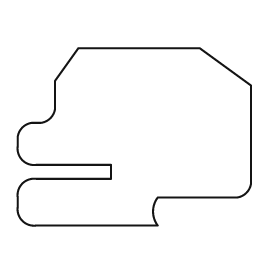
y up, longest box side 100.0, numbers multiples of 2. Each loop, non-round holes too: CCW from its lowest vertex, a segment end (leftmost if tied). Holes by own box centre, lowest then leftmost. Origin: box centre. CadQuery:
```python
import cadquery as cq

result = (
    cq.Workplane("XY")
    .moveTo(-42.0, -38.0)
    .lineTo(10.0, -38.0)
    .threePointArc((8.0, -32.0), (10.0, -26.0))
    .lineTo(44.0, -26.0)
    .threePointArc((48.0, -24.0), (50.0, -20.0))
    .lineTo(50.0, 22.0)
    .lineTo(28.0, 38.0)
    .lineTo(-24.0, 38.0)
    .lineTo(-34.0, 24.0)
    .lineTo(-34.0, 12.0)
    .threePointArc((-36.0, 8.0), (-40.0, 6.0))
    .lineTo(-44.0, 6.0)
    .threePointArc((-48.0, 4.0), (-50.0, 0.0))
    .lineTo(-50.0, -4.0)
    .threePointArc((-48.0, -10.0), (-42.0, -12.0))
    .lineTo(-10.0, -12.0)
    .lineTo(-10.0, -18.0)
    .lineTo(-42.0, -18.0)
    .threePointArc((-48.0, -20.0), (-50.0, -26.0))
    .lineTo(-50.0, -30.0)
    .threePointArc((-48.0, -36.0), (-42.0, -38.0))
    .close()
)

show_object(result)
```